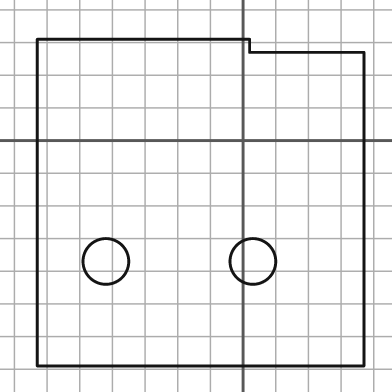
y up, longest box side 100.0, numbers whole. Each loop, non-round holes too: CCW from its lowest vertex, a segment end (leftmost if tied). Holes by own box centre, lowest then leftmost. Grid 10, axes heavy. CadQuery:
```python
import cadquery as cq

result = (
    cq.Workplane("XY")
    .moveTo(-63.0, -69.0)
    .lineTo(37.0, -69.0)
    .lineTo(37.0, 27.0)
    .lineTo(2.0, 27.0)
    .lineTo(2.0, 31.0)
    .lineTo(-63.0, 31.0)
    .close()
    .moveTo(-42.0, -37.0)
    .circle(7.0)
    .moveTo(3.0, -37.0)
    .circle(7.0)
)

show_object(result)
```